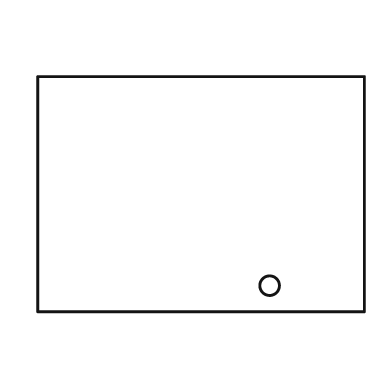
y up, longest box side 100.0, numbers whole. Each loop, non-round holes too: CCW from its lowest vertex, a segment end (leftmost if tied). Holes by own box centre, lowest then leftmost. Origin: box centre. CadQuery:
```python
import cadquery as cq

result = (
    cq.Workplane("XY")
    .moveTo(-50.0, -36.0)
    .lineTo(50.0, -36.0)
    .lineTo(50.0, 36.0)
    .lineTo(-50.0, 36.0)
    .close()
    .moveTo(21.0, -28.0)
    .circle(3.0)
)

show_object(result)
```